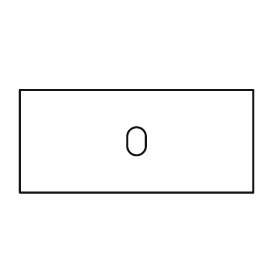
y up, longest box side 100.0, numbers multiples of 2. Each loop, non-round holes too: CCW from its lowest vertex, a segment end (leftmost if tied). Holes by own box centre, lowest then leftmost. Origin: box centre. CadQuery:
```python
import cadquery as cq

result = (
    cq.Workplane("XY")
    .moveTo(-50.0, -22.0)
    .lineTo(50.0, -22.0)
    .lineTo(50.0, 22.0)
    .lineTo(-50.0, 22.0)
    .close()
    .moveTo(-4.0, -2.0)
    .threePointArc((0.0, -6.0), (4.0, -2.0))
    .lineTo(4.0, 2.0)
    .threePointArc((0.0, 6.0), (-4.0, 2.0))
    .close()
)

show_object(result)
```